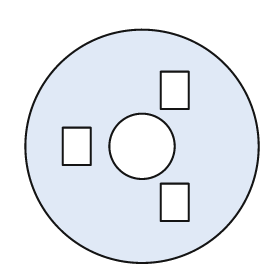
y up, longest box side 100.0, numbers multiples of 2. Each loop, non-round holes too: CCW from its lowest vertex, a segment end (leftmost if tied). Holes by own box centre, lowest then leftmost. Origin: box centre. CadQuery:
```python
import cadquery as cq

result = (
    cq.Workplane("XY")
    .moveTo(0.0, 0.0)
    .circle(50.0)
    .moveTo(8.0, -32.0)
    .lineTo(20.0, -32.0)
    .lineTo(20.0, -16.0)
    .lineTo(8.0, -16.0)
    .close()
    .moveTo(-34.0, -8.0)
    .lineTo(-22.0, -8.0)
    .lineTo(-22.0, 8.0)
    .lineTo(-34.0, 8.0)
    .close()
    .moveTo(0.0, 0.0)
    .circle(14.0)
    .moveTo(8.0, 16.0)
    .lineTo(20.0, 16.0)
    .lineTo(20.0, 32.0)
    .lineTo(8.0, 32.0)
    .close()
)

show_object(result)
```